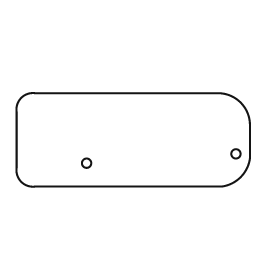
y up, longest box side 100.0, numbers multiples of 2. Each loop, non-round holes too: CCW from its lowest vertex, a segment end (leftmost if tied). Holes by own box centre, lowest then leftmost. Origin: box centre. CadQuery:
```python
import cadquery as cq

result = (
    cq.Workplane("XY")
    .moveTo(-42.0, -20.0)
    .lineTo(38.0, -20.0)
    .threePointArc((46.0, -16.0), (50.0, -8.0))
    .lineTo(50.0, 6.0)
    .threePointArc((46.0, 16.0), (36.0, 20.0))
    .lineTo(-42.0, 20.0)
    .threePointArc((-48.0, 18.0), (-50.0, 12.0))
    .lineTo(-50.0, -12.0)
    .threePointArc((-48.0, -18.0), (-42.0, -20.0))
    .close()
    .moveTo(-20.0, -10.0)
    .circle(2.0)
    .moveTo(44.0, -6.0)
    .circle(2.0)
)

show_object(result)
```